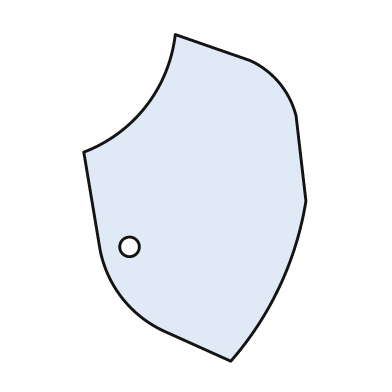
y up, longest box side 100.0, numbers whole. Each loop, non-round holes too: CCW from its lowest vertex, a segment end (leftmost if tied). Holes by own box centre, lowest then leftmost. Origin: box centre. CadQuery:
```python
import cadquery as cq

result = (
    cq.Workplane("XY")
    .moveTo(11.0, -50.0)
    .threePointArc((26.0, -27.0), (34.0, -1.0))
    .lineTo(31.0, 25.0)
    .threePointArc((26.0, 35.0), (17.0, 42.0))
    .lineTo(-6.0, 50.0)
    .threePointArc((-15.0, 28.0), (-34.0, 14.0))
    .lineTo(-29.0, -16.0)
    .threePointArc((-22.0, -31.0), (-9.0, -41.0))
    .close()
    .moveTo(-20.0, -15.0)
    .circle(3.0)
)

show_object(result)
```